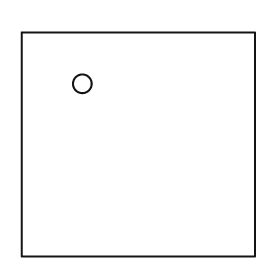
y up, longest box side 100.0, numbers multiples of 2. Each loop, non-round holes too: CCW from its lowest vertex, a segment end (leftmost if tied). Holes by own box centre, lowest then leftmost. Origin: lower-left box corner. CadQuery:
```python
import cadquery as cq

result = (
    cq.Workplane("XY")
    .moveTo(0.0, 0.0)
    .lineTo(100.0, 0.0)
    .lineTo(100.0, 96.0)
    .lineTo(0.0, 96.0)
    .close()
    .moveTo(26.0, 74.0)
    .circle(4.0)
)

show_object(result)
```